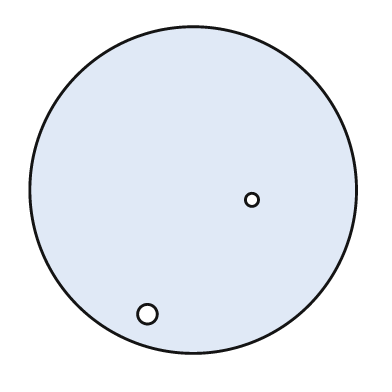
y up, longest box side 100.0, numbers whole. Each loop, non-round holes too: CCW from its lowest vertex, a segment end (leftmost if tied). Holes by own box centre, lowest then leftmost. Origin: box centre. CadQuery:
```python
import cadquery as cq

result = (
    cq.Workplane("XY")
    .moveTo(0.0, 0.0)
    .circle(50.0)
    .moveTo(-14.0, -38.0)
    .circle(3.0)
    .moveTo(18.0, -3.0)
    .circle(2.0)
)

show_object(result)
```